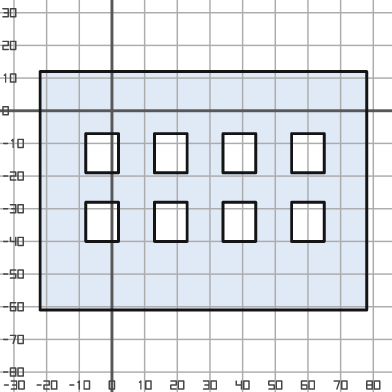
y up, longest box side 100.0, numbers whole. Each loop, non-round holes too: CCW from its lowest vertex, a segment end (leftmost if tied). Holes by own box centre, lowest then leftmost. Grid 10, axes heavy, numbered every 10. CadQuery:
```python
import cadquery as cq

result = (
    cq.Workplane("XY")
    .moveTo(-22.0, -61.0)
    .lineTo(78.0, -61.0)
    .lineTo(78.0, 12.0)
    .lineTo(-22.0, 12.0)
    .close()
    .moveTo(-8.0, -40.0)
    .lineTo(2.0, -40.0)
    .lineTo(2.0, -28.0)
    .lineTo(-8.0, -28.0)
    .close()
    .moveTo(13.0, -40.0)
    .lineTo(23.0, -40.0)
    .lineTo(23.0, -28.0)
    .lineTo(13.0, -28.0)
    .close()
    .moveTo(34.0, -40.0)
    .lineTo(44.0, -40.0)
    .lineTo(44.0, -28.0)
    .lineTo(34.0, -28.0)
    .close()
    .moveTo(55.0, -40.0)
    .lineTo(65.0, -40.0)
    .lineTo(65.0, -28.0)
    .lineTo(55.0, -28.0)
    .close()
    .moveTo(-8.0, -19.0)
    .lineTo(2.0, -19.0)
    .lineTo(2.0, -7.0)
    .lineTo(-8.0, -7.0)
    .close()
    .moveTo(13.0, -19.0)
    .lineTo(23.0, -19.0)
    .lineTo(23.0, -7.0)
    .lineTo(13.0, -7.0)
    .close()
    .moveTo(34.0, -19.0)
    .lineTo(44.0, -19.0)
    .lineTo(44.0, -7.0)
    .lineTo(34.0, -7.0)
    .close()
    .moveTo(55.0, -19.0)
    .lineTo(65.0, -19.0)
    .lineTo(65.0, -7.0)
    .lineTo(55.0, -7.0)
    .close()
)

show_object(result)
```